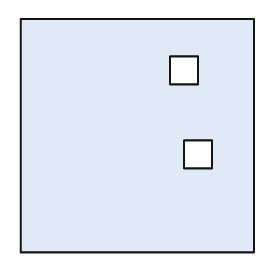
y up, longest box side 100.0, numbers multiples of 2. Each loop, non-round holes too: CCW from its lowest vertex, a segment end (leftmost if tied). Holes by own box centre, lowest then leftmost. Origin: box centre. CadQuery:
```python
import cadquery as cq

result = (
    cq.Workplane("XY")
    .moveTo(-50.0, -50.0)
    .lineTo(50.0, -50.0)
    .lineTo(50.0, 50.0)
    .lineTo(-50.0, 50.0)
    .close()
    .moveTo(20.0, -14.0)
    .lineTo(32.0, -14.0)
    .lineTo(32.0, -2.0)
    .lineTo(20.0, -2.0)
    .close()
    .moveTo(14.0, 22.0)
    .lineTo(26.0, 22.0)
    .lineTo(26.0, 34.0)
    .lineTo(14.0, 34.0)
    .close()
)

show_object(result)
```